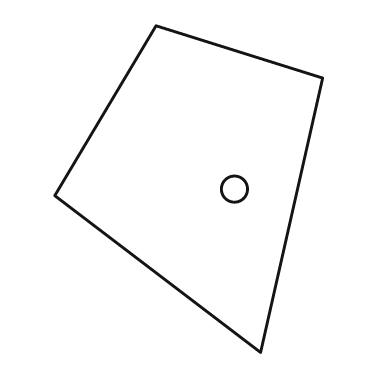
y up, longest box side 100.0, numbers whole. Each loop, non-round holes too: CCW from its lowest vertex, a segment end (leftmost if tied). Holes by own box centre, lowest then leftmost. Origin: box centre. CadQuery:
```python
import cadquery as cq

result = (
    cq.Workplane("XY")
    .moveTo(22.0, -50.0)
    .lineTo(41.0, 34.0)
    .lineTo(-10.0, 50.0)
    .lineTo(-41.0, -2.0)
    .close()
    .moveTo(14.0, 0.0)
    .circle(4.0)
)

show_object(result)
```